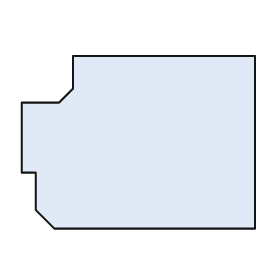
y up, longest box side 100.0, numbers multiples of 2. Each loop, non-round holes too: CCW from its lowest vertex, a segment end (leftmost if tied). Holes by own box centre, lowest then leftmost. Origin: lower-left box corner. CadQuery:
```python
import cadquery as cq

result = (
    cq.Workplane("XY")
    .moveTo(14.0, 0.0)
    .lineTo(100.0, 0.0)
    .lineTo(100.0, 74.0)
    .lineTo(22.0, 74.0)
    .lineTo(22.0, 60.0)
    .lineTo(16.0, 54.0)
    .lineTo(0.0, 54.0)
    .lineTo(0.0, 24.0)
    .lineTo(6.0, 24.0)
    .lineTo(6.0, 8.0)
    .close()
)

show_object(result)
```